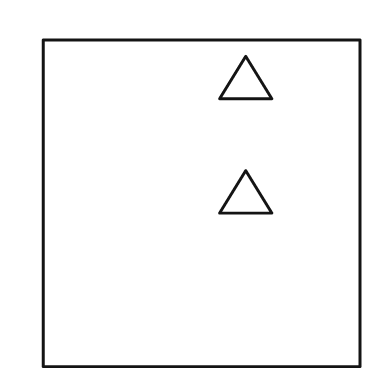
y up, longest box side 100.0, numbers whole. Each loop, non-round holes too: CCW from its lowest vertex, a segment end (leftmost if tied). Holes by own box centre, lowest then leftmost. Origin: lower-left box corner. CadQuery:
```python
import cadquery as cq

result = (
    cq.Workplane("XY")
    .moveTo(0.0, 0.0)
    .lineTo(97.0, 0.0)
    .lineTo(97.0, 100.0)
    .lineTo(0.0, 100.0)
    .close()
    .moveTo(54.0, 47.0)
    .lineTo(70.0, 47.0)
    .lineTo(62.0, 60.0)
    .close()
    .moveTo(54.0, 82.0)
    .lineTo(70.0, 82.0)
    .lineTo(62.0, 95.0)
    .close()
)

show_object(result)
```